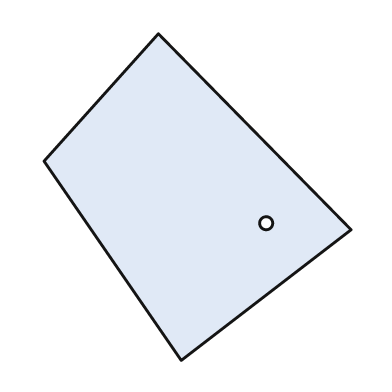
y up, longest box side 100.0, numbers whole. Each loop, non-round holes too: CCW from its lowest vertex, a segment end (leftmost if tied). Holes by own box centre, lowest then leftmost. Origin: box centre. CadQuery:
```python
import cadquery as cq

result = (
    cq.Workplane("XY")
    .moveTo(-5.0, -50.0)
    .lineTo(47.0, -10.0)
    .lineTo(-12.0, 50.0)
    .lineTo(-47.0, 11.0)
    .close()
    .moveTo(21.0, -8.0)
    .circle(2.0)
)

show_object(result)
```